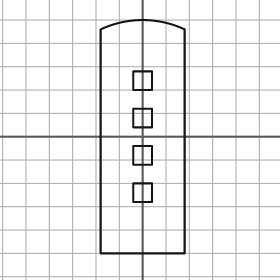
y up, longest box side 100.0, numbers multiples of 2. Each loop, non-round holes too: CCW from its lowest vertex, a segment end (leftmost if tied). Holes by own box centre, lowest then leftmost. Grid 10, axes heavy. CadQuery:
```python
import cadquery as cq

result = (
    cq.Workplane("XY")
    .moveTo(-18.0, -50.0)
    .lineTo(18.0, -50.0)
    .lineTo(18.0, 46.0)
    .threePointArc((0.0, 50.0), (-18.0, 46.0))
    .close()
    .moveTo(-4.0, -28.0)
    .lineTo(4.0, -28.0)
    .lineTo(4.0, -20.0)
    .lineTo(-4.0, -20.0)
    .close()
    .moveTo(-4.0, -12.0)
    .lineTo(4.0, -12.0)
    .lineTo(4.0, -4.0)
    .lineTo(-4.0, -4.0)
    .close()
    .moveTo(-4.0, 4.0)
    .lineTo(4.0, 4.0)
    .lineTo(4.0, 12.0)
    .lineTo(-4.0, 12.0)
    .close()
    .moveTo(-4.0, 20.0)
    .lineTo(4.0, 20.0)
    .lineTo(4.0, 28.0)
    .lineTo(-4.0, 28.0)
    .close()
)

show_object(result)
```